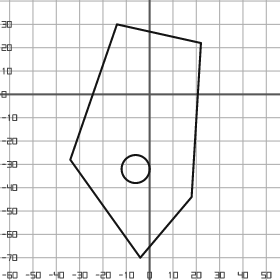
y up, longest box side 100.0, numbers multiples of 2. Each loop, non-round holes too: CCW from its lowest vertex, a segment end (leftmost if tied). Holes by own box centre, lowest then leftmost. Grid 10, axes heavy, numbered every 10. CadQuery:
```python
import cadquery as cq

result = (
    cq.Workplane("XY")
    .moveTo(-4.0, -70.0)
    .lineTo(18.0, -44.0)
    .lineTo(22.0, 22.0)
    .lineTo(-14.0, 30.0)
    .lineTo(-34.0, -28.0)
    .close()
    .moveTo(-6.0, -32.0)
    .circle(6.0)
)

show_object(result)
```